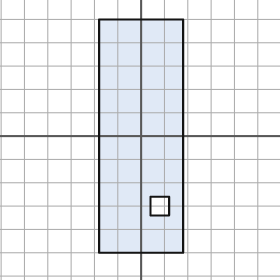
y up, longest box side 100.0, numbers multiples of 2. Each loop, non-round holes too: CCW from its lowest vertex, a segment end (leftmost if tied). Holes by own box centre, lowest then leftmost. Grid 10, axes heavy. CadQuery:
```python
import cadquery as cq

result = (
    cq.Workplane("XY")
    .moveTo(-18.0, -50.0)
    .lineTo(18.0, -50.0)
    .lineTo(18.0, 50.0)
    .lineTo(-18.0, 50.0)
    .close()
    .moveTo(4.0, -34.0)
    .lineTo(12.0, -34.0)
    .lineTo(12.0, -26.0)
    .lineTo(4.0, -26.0)
    .close()
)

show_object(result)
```